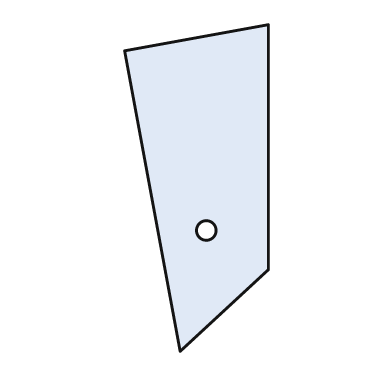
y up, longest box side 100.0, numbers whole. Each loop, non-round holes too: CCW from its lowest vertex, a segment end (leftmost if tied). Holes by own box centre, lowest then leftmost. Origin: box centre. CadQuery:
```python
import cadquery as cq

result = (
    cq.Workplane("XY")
    .moveTo(-5.0, -50.0)
    .lineTo(22.0, -25.0)
    .lineTo(22.0, 50.0)
    .lineTo(-22.0, 42.0)
    .close()
    .moveTo(3.0, -13.0)
    .circle(3.0)
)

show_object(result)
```